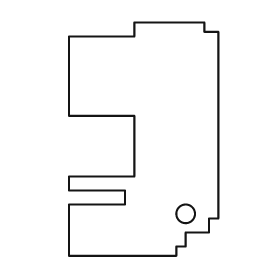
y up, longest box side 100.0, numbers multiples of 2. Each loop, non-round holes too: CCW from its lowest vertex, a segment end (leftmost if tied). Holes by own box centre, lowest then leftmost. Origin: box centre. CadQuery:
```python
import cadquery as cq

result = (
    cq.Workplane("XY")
    .moveTo(-32.0, -50.0)
    .lineTo(14.0, -50.0)
    .lineTo(14.0, -46.0)
    .lineTo(18.0, -46.0)
    .lineTo(18.0, -40.0)
    .lineTo(28.0, -40.0)
    .lineTo(28.0, -34.0)
    .lineTo(32.0, -34.0)
    .lineTo(32.0, 46.0)
    .lineTo(26.0, 46.0)
    .lineTo(26.0, 50.0)
    .lineTo(-4.0, 50.0)
    .lineTo(-4.0, 44.0)
    .lineTo(-32.0, 44.0)
    .lineTo(-32.0, 10.0)
    .lineTo(-4.0, 10.0)
    .lineTo(-4.0, -16.0)
    .lineTo(-32.0, -16.0)
    .lineTo(-32.0, -22.0)
    .lineTo(-8.0, -22.0)
    .lineTo(-8.0, -28.0)
    .lineTo(-32.0, -28.0)
    .close()
    .moveTo(18.0, -32.0)
    .circle(4.0)
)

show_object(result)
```